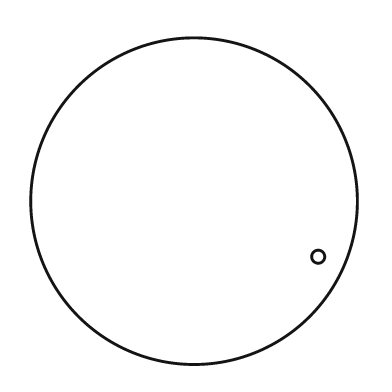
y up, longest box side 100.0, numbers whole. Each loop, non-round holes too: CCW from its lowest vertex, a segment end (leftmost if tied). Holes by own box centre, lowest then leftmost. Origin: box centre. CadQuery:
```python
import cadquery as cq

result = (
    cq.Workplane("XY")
    .moveTo(0.0, 0.0)
    .circle(50.0)
    .moveTo(38.0, -17.0)
    .circle(2.0)
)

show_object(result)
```